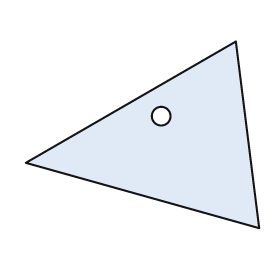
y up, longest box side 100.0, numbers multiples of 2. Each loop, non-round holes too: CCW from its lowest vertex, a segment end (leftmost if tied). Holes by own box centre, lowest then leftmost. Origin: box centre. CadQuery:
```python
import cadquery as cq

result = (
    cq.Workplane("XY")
    .moveTo(50.0, -40.0)
    .lineTo(40.0, 40.0)
    .lineTo(-50.0, -12.0)
    .close()
    .moveTo(8.0, 8.0)
    .circle(4.0)
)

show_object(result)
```